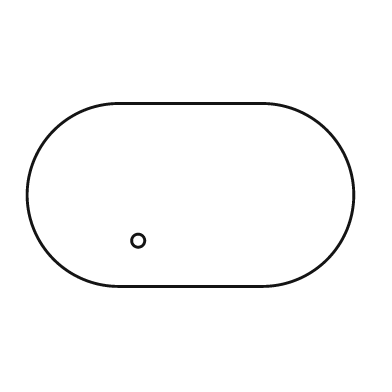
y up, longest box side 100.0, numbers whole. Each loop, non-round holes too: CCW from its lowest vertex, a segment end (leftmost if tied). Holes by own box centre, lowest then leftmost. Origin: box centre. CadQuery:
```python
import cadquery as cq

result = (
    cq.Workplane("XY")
    .moveTo(-22.0, -28.0)
    .lineTo(22.0, -28.0)
    .threePointArc((50.0, 0.0), (22.0, 28.0))
    .lineTo(-22.0, 28.0)
    .threePointArc((-50.0, 0.0), (-22.0, -28.0))
    .close()
    .moveTo(-16.0, -14.0)
    .circle(2.0)
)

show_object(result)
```